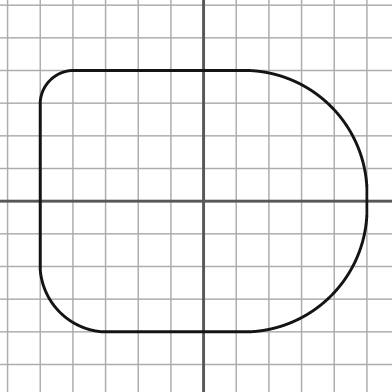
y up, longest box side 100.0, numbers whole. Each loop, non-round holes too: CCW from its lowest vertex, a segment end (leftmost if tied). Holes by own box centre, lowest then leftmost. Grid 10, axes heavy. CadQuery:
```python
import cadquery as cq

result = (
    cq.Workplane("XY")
    .moveTo(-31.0, -40.0)
    .lineTo(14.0, -40.0)
    .threePointArc((39.0, -29.0), (50.0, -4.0))
    .lineTo(50.0, 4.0)
    .threePointArc((39.0, 29.0), (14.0, 40.0))
    .lineTo(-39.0, 40.0)
    .threePointArc((-47.0, 37.0), (-50.0, 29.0))
    .lineTo(-50.0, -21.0)
    .threePointArc((-44.0, -34.0), (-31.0, -40.0))
    .close()
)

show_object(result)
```